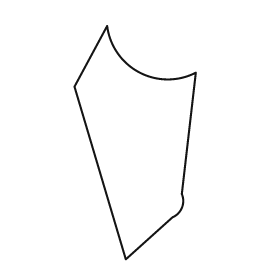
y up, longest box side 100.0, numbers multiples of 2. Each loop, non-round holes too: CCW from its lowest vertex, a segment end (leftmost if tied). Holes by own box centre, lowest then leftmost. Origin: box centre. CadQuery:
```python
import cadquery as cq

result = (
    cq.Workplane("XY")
    .moveTo(-4.0, -50.0)
    .lineTo(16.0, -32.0)
    .threePointArc((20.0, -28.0), (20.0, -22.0))
    .lineTo(26.0, 30.0)
    .threePointArc((2.0, 30.0), (-12.0, 50.0))
    .lineTo(-26.0, 24.0)
    .close()
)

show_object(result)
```